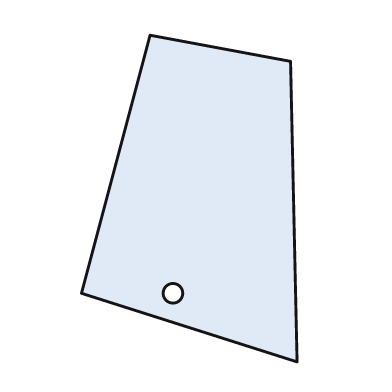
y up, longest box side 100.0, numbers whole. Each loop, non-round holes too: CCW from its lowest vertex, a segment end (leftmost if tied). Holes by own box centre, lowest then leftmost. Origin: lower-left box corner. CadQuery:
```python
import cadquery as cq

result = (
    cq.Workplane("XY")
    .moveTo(66.0, 0.0)
    .lineTo(64.0, 92.0)
    .lineTo(21.0, 100.0)
    .lineTo(0.0, 21.0)
    .close()
    .moveTo(28.0, 21.0)
    .circle(3.0)
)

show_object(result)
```